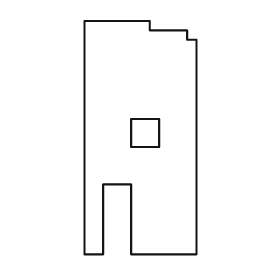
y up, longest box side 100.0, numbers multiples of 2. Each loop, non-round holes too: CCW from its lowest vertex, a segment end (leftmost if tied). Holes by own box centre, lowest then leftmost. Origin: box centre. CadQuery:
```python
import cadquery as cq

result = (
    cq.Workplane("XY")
    .moveTo(-24.0, -50.0)
    .lineTo(-16.0, -50.0)
    .lineTo(-16.0, -20.0)
    .lineTo(-4.0, -20.0)
    .lineTo(-4.0, -50.0)
    .lineTo(24.0, -50.0)
    .lineTo(24.0, 42.0)
    .lineTo(20.0, 42.0)
    .lineTo(20.0, 46.0)
    .lineTo(4.0, 46.0)
    .lineTo(4.0, 50.0)
    .lineTo(-24.0, 50.0)
    .close()
    .moveTo(-4.0, -4.0)
    .lineTo(8.0, -4.0)
    .lineTo(8.0, 8.0)
    .lineTo(-4.0, 8.0)
    .close()
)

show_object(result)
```